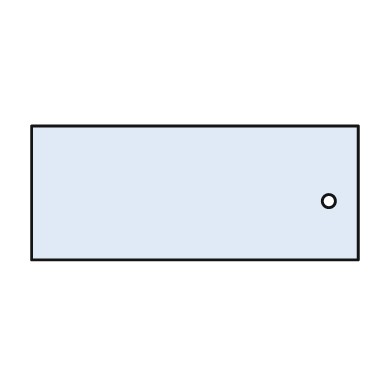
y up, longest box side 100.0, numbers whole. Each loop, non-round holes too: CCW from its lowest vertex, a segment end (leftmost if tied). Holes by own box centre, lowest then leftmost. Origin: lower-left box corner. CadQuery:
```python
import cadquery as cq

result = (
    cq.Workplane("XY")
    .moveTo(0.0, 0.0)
    .lineTo(100.0, 0.0)
    .lineTo(100.0, 41.0)
    .lineTo(0.0, 41.0)
    .close()
    .moveTo(91.0, 18.0)
    .circle(2.0)
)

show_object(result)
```